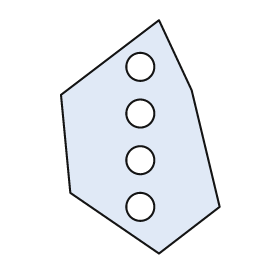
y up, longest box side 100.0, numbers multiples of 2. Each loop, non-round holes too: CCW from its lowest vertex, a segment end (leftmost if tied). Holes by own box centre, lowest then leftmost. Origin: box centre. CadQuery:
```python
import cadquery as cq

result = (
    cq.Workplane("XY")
    .moveTo(8.0, -50.0)
    .lineTo(34.0, -30.0)
    .lineTo(22.0, 20.0)
    .lineTo(8.0, 50.0)
    .lineTo(-34.0, 18.0)
    .lineTo(-30.0, -24.0)
    .close()
    .moveTo(0.0, -30.0)
    .circle(6.0)
    .moveTo(0.0, -10.0)
    .circle(6.0)
    .moveTo(0.0, 10.0)
    .circle(6.0)
    .moveTo(0.0, 30.0)
    .circle(6.0)
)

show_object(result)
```